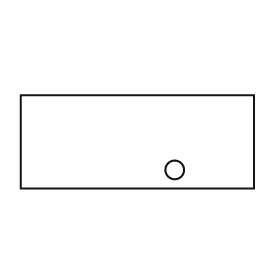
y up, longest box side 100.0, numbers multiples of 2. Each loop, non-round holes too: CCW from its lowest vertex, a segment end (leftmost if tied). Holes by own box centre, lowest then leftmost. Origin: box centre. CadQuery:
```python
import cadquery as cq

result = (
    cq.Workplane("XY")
    .moveTo(-50.0, -20.0)
    .lineTo(50.0, -20.0)
    .lineTo(50.0, 20.0)
    .lineTo(-50.0, 20.0)
    .close()
    .moveTo(16.0, -12.0)
    .circle(4.0)
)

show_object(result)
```